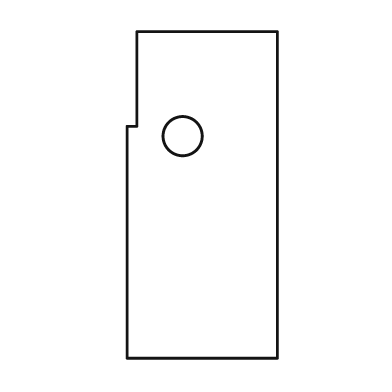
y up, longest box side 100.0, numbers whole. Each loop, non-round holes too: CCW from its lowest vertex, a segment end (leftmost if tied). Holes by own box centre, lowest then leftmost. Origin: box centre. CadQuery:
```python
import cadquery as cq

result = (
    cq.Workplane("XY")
    .moveTo(-23.0, -50.0)
    .lineTo(23.0, -50.0)
    .lineTo(23.0, 50.0)
    .lineTo(-20.0, 50.0)
    .lineTo(-20.0, 21.0)
    .lineTo(-23.0, 21.0)
    .close()
    .moveTo(-6.0, 18.0)
    .circle(6.0)
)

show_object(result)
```